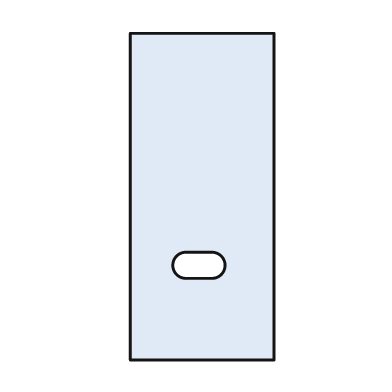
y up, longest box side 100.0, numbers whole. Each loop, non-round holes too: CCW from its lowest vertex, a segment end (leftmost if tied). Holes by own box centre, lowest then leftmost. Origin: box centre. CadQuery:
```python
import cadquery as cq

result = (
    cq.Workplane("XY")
    .moveTo(-22.0, -50.0)
    .lineTo(22.0, -50.0)
    .lineTo(22.0, 50.0)
    .lineTo(-22.0, 50.0)
    .close()
    .moveTo(-5.0, -25.0)
    .lineTo(3.0, -25.0)
    .threePointArc((7.0, -21.0), (3.0, -17.0))
    .lineTo(-5.0, -17.0)
    .threePointArc((-9.0, -21.0), (-5.0, -25.0))
    .close()
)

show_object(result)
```